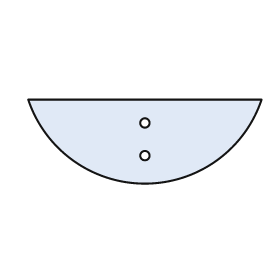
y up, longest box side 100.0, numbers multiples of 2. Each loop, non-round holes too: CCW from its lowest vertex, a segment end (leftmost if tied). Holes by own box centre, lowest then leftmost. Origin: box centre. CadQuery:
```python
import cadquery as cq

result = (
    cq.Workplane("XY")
    .moveTo(-50.0, 18.0)
    .threePointArc((0.0, -18.0), (50.0, 18.0))
    .close()
    .moveTo(0.0, -6.0)
    .circle(2.0)
    .moveTo(0.0, 8.0)
    .circle(2.0)
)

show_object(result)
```